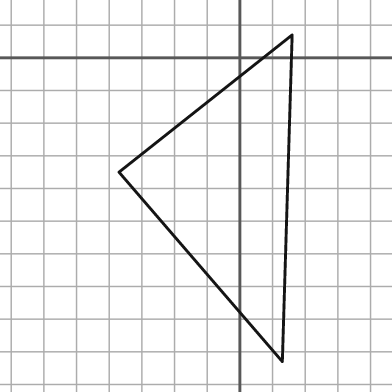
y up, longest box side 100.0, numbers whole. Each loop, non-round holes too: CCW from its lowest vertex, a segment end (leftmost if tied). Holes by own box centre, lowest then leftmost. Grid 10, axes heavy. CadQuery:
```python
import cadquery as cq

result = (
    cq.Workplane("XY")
    .moveTo(13.0, -93.0)
    .lineTo(16.0, 7.0)
    .lineTo(-37.0, -35.0)
    .close()
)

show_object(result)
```